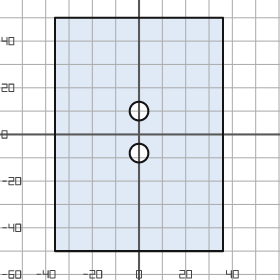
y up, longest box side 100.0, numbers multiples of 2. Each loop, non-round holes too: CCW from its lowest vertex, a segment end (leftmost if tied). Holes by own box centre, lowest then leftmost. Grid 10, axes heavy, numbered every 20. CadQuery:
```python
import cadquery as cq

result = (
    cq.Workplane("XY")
    .moveTo(-36.0, -50.0)
    .lineTo(36.0, -50.0)
    .lineTo(36.0, 50.0)
    .lineTo(-36.0, 50.0)
    .close()
    .moveTo(0.0, -8.0)
    .circle(4.0)
    .moveTo(0.0, 10.0)
    .circle(4.0)
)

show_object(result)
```